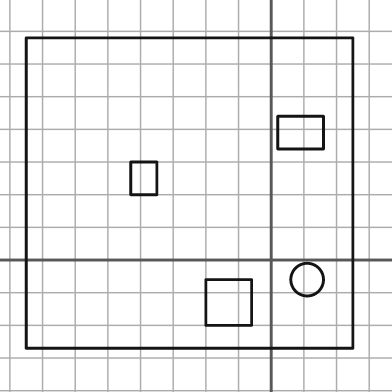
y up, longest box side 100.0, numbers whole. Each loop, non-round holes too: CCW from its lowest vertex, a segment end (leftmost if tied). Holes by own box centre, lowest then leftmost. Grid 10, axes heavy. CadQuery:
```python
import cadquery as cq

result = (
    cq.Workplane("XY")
    .moveTo(-75.0, -27.0)
    .lineTo(25.0, -27.0)
    .lineTo(25.0, 68.0)
    .lineTo(-75.0, 68.0)
    .close()
    .moveTo(-20.0, -20.0)
    .lineTo(-6.0, -20.0)
    .lineTo(-6.0, -6.0)
    .lineTo(-20.0, -6.0)
    .close()
    .moveTo(11.0, -6.0)
    .circle(5.0)
    .moveTo(-43.0, 20.0)
    .lineTo(-35.0, 20.0)
    .lineTo(-35.0, 30.0)
    .lineTo(-43.0, 30.0)
    .close()
    .moveTo(2.0, 34.0)
    .lineTo(16.0, 34.0)
    .lineTo(16.0, 44.0)
    .lineTo(2.0, 44.0)
    .close()
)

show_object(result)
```